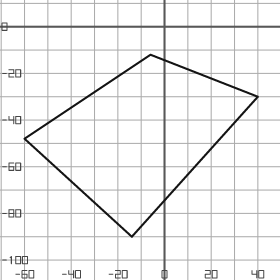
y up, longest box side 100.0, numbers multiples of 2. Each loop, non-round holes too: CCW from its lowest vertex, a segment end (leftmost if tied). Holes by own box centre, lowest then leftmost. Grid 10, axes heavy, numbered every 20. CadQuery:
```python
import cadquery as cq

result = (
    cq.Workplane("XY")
    .moveTo(-14.0, -90.0)
    .lineTo(40.0, -30.0)
    .lineTo(-6.0, -12.0)
    .lineTo(-60.0, -48.0)
    .close()
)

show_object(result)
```